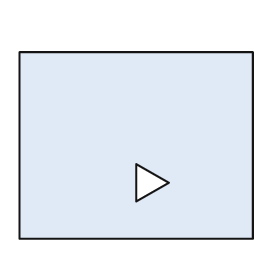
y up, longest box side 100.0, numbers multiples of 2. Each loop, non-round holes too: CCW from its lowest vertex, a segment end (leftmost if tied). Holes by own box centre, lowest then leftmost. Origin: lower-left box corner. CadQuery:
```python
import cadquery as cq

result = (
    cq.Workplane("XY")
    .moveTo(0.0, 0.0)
    .lineTo(100.0, 0.0)
    .lineTo(100.0, 80.0)
    .lineTo(0.0, 80.0)
    .close()
    .moveTo(50.0, 16.0)
    .lineTo(64.0, 24.0)
    .lineTo(50.0, 32.0)
    .close()
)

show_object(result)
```